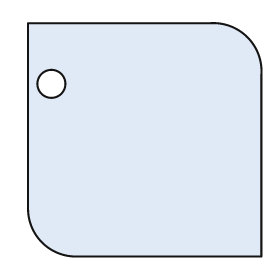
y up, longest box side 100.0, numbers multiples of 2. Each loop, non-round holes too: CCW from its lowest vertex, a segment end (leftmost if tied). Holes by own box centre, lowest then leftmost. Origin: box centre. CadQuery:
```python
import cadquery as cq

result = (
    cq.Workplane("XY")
    .moveTo(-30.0, -50.0)
    .lineTo(50.0, -50.0)
    .lineTo(50.0, 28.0)
    .threePointArc((44.0, 44.0), (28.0, 50.0))
    .lineTo(-50.0, 50.0)
    .lineTo(-50.0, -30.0)
    .threePointArc((-44.0, -44.0), (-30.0, -50.0))
    .close()
    .moveTo(-40.0, 24.0)
    .circle(6.0)
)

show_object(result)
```